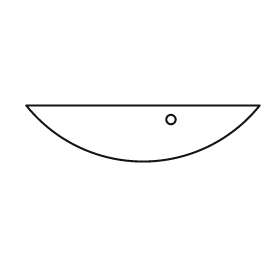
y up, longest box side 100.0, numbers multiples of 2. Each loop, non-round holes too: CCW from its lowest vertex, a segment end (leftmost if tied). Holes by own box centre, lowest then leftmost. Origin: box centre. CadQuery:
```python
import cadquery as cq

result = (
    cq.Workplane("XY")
    .moveTo(-50.0, 12.0)
    .threePointArc((0.0, -12.0), (50.0, 12.0))
    .close()
    .moveTo(12.0, 6.0)
    .circle(2.0)
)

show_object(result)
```